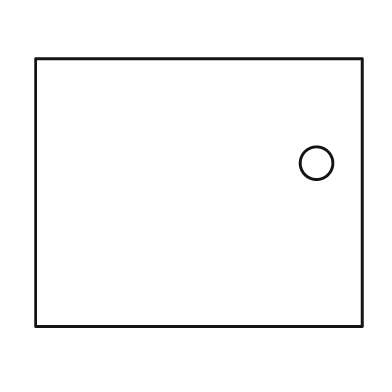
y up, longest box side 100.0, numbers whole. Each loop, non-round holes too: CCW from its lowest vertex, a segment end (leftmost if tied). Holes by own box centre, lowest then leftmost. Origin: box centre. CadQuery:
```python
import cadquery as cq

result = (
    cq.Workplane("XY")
    .moveTo(-50.0, -41.0)
    .lineTo(50.0, -41.0)
    .lineTo(50.0, 41.0)
    .lineTo(-50.0, 41.0)
    .close()
    .moveTo(36.0, 9.0)
    .circle(5.0)
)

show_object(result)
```